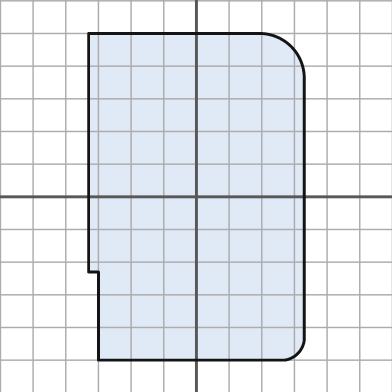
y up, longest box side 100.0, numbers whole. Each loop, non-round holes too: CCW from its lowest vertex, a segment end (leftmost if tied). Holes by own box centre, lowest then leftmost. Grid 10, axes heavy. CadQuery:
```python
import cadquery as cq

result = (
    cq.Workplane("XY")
    .moveTo(-30.0, -50.0)
    .lineTo(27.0, -50.0)
    .threePointArc((31.0, -48.0), (33.0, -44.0))
    .lineTo(33.0, 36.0)
    .threePointArc((29.0, 46.0), (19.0, 50.0))
    .lineTo(-33.0, 50.0)
    .lineTo(-33.0, -23.0)
    .lineTo(-30.0, -23.0)
    .close()
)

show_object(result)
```